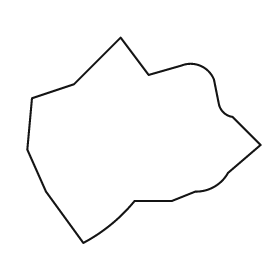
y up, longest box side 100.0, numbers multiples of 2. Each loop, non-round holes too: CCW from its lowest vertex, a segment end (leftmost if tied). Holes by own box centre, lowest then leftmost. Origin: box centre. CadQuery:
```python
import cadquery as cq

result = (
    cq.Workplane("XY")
    .moveTo(-26.0, -44.0)
    .threePointArc((-14.0, -36.0), (-4.0, -26.0))
    .lineTo(12.0, -26.0)
    .lineTo(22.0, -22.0)
    .threePointArc((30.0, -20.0), (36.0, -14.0))
    .lineTo(50.0, -2.0)
    .lineTo(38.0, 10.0)
    .threePointArc((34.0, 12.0), (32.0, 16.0))
    .lineTo(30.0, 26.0)
    .threePointArc((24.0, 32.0), (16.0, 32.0))
    .lineTo(2.0, 28.0)
    .lineTo(-10.0, 44.0)
    .lineTo(-30.0, 24.0)
    .lineTo(-48.0, 18.0)
    .lineTo(-50.0, -4.0)
    .lineTo(-42.0, -22.0)
    .close()
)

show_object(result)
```